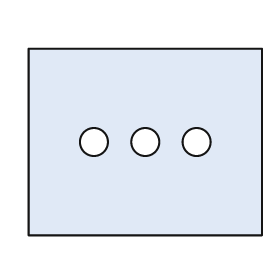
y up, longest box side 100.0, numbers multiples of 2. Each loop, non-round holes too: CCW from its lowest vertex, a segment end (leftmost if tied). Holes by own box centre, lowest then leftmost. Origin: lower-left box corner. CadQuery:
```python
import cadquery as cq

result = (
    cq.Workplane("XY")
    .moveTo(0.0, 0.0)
    .lineTo(100.0, 0.0)
    .lineTo(100.0, 80.0)
    .lineTo(0.0, 80.0)
    .close()
    .moveTo(28.0, 40.0)
    .circle(6.0)
    .moveTo(50.0, 40.0)
    .circle(6.0)
    .moveTo(72.0, 40.0)
    .circle(6.0)
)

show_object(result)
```